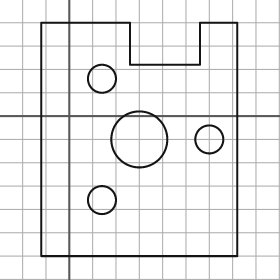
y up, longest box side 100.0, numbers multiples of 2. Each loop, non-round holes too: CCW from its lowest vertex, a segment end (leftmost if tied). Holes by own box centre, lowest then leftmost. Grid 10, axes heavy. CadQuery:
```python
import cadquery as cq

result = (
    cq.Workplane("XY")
    .moveTo(-12.0, -60.0)
    .lineTo(72.0, -60.0)
    .lineTo(72.0, 40.0)
    .lineTo(56.0, 40.0)
    .lineTo(56.0, 22.0)
    .lineTo(26.0, 22.0)
    .lineTo(26.0, 40.0)
    .lineTo(-12.0, 40.0)
    .close()
    .moveTo(14.0, -36.0)
    .circle(6.0)
    .moveTo(30.0, -10.0)
    .circle(12.0)
    .moveTo(60.0, -10.0)
    .circle(6.0)
    .moveTo(14.0, 16.0)
    .circle(6.0)
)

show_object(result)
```